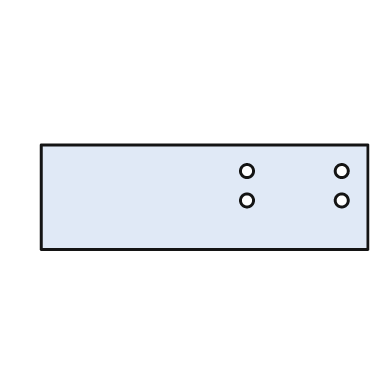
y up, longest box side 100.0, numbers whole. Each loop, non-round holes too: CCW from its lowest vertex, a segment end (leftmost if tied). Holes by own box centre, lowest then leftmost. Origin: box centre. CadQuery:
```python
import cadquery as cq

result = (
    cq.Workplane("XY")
    .moveTo(-50.0, -16.0)
    .lineTo(50.0, -16.0)
    .lineTo(50.0, 16.0)
    .lineTo(-50.0, 16.0)
    .close()
    .moveTo(13.0, -1.0)
    .circle(2.0)
    .moveTo(42.0, -1.0)
    .circle(2.0)
    .moveTo(13.0, 8.0)
    .circle(2.0)
    .moveTo(42.0, 8.0)
    .circle(2.0)
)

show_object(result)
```